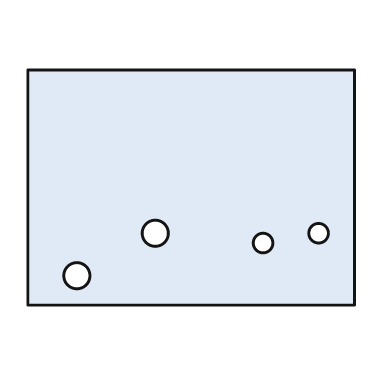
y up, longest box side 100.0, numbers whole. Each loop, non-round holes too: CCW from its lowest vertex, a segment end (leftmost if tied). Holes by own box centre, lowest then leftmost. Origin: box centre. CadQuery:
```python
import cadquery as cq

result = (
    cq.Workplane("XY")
    .moveTo(-50.0, -36.0)
    .lineTo(50.0, -36.0)
    .lineTo(50.0, 36.0)
    .lineTo(-50.0, 36.0)
    .close()
    .moveTo(-35.0, -27.0)
    .circle(4.0)
    .moveTo(22.0, -17.0)
    .circle(3.0)
    .moveTo(-11.0, -14.0)
    .circle(4.0)
    .moveTo(39.0, -14.0)
    .circle(3.0)
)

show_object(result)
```